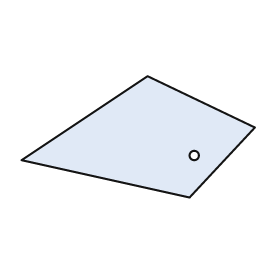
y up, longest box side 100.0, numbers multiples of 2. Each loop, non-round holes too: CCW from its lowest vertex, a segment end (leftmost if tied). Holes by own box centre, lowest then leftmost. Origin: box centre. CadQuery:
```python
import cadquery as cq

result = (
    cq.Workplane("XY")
    .moveTo(22.0, -26.0)
    .lineTo(50.0, 4.0)
    .lineTo(4.0, 26.0)
    .lineTo(-50.0, -10.0)
    .close()
    .moveTo(24.0, -8.0)
    .circle(2.0)
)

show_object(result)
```